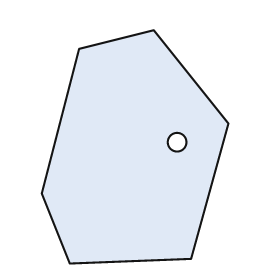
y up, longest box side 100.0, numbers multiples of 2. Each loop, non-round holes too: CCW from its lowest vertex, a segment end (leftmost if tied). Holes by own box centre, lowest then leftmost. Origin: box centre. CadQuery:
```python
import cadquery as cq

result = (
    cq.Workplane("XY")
    .moveTo(-28.0, -50.0)
    .lineTo(24.0, -48.0)
    .lineTo(40.0, 10.0)
    .lineTo(8.0, 50.0)
    .lineTo(-24.0, 42.0)
    .lineTo(-40.0, -20.0)
    .close()
    .moveTo(18.0, 2.0)
    .circle(4.0)
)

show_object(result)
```